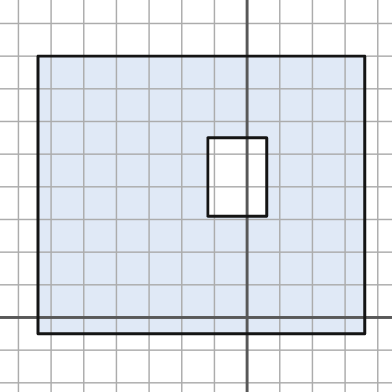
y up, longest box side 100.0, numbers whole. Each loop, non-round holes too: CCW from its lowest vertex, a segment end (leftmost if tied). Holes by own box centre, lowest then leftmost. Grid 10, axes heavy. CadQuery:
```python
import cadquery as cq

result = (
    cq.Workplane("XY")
    .moveTo(-64.0, -5.0)
    .lineTo(36.0, -5.0)
    .lineTo(36.0, 80.0)
    .lineTo(-64.0, 80.0)
    .close()
    .moveTo(-12.0, 31.0)
    .lineTo(6.0, 31.0)
    .lineTo(6.0, 55.0)
    .lineTo(-12.0, 55.0)
    .close()
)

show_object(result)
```